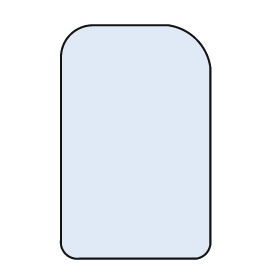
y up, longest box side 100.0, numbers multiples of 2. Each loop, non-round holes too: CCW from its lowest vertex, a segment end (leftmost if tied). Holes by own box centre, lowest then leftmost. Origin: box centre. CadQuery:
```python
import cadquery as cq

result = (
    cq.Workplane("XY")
    .moveTo(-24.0, -50.0)
    .lineTo(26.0, -50.0)
    .threePointArc((30.0, -48.0), (32.0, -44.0))
    .lineTo(32.0, 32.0)
    .threePointArc((26.0, 44.0), (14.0, 50.0))
    .lineTo(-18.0, 50.0)
    .threePointArc((-28.0, 46.0), (-32.0, 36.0))
    .lineTo(-32.0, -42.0)
    .threePointArc((-30.0, -48.0), (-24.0, -50.0))
    .close()
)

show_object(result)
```